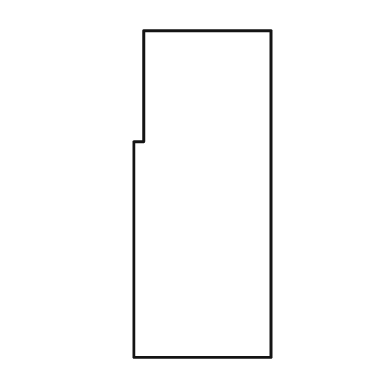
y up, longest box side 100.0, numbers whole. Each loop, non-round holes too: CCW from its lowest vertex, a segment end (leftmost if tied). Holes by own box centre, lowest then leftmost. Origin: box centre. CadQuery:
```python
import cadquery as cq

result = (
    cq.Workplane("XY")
    .moveTo(-21.0, -50.0)
    .lineTo(21.0, -50.0)
    .lineTo(21.0, 50.0)
    .lineTo(-18.0, 50.0)
    .lineTo(-18.0, 16.0)
    .lineTo(-21.0, 16.0)
    .close()
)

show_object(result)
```